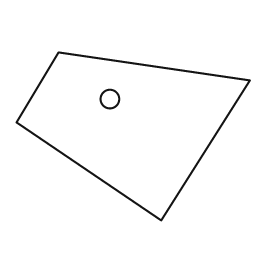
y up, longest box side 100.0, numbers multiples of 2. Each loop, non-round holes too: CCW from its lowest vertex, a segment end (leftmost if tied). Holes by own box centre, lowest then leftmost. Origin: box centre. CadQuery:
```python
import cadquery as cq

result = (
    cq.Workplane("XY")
    .moveTo(12.0, -36.0)
    .lineTo(50.0, 24.0)
    .lineTo(-32.0, 36.0)
    .lineTo(-50.0, 6.0)
    .close()
    .moveTo(-10.0, 16.0)
    .circle(4.0)
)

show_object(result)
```